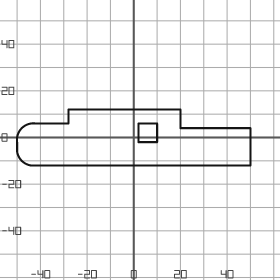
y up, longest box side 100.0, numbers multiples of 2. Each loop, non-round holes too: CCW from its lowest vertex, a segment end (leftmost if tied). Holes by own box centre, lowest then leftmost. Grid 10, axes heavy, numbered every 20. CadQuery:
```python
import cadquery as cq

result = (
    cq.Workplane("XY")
    .moveTo(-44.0, -12.0)
    .lineTo(50.0, -12.0)
    .lineTo(50.0, 4.0)
    .lineTo(20.0, 4.0)
    .lineTo(20.0, 12.0)
    .lineTo(-28.0, 12.0)
    .lineTo(-28.0, 6.0)
    .lineTo(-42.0, 6.0)
    .threePointArc((-48.0, 4.0), (-50.0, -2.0))
    .lineTo(-50.0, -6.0)
    .threePointArc((-48.0, -10.0), (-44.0, -12.0))
    .close()
    .moveTo(2.0, -2.0)
    .lineTo(10.0, -2.0)
    .lineTo(10.0, 6.0)
    .lineTo(2.0, 6.0)
    .close()
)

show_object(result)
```